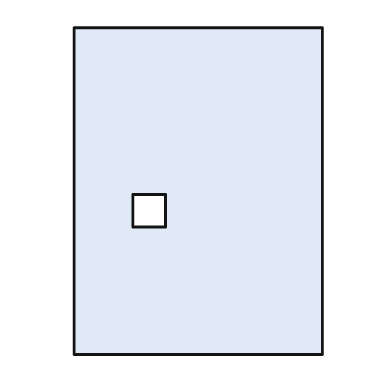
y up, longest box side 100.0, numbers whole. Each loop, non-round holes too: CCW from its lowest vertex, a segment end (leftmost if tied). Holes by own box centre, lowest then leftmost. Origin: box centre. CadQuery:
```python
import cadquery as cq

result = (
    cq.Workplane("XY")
    .moveTo(-38.0, -50.0)
    .lineTo(38.0, -50.0)
    .lineTo(38.0, 50.0)
    .lineTo(-38.0, 50.0)
    .close()
    .moveTo(-20.0, -11.0)
    .lineTo(-10.0, -11.0)
    .lineTo(-10.0, -1.0)
    .lineTo(-20.0, -1.0)
    .close()
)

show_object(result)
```